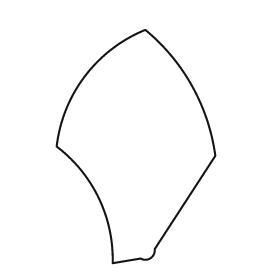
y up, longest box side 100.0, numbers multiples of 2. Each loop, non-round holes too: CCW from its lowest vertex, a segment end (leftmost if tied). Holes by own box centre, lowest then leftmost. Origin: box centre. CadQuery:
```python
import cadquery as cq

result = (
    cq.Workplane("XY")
    .moveTo(-10.0, -50.0)
    .lineTo(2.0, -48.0)
    .threePointArc((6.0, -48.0), (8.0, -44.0))
    .lineTo(34.0, -4.0)
    .threePointArc((24.0, 26.0), (4.0, 50.0))
    .threePointArc((-22.0, 30.0), (-34.0, 0.0))
    .threePointArc((-16.0, -22.0), (-10.0, -50.0))
    .close()
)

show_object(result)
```